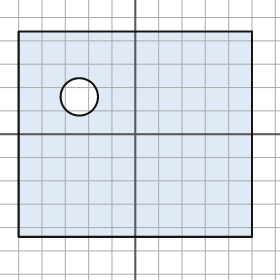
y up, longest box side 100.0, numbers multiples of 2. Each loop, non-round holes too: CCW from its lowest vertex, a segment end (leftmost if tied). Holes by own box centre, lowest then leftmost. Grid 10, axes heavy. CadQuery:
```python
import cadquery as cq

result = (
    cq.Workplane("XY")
    .moveTo(-50.0, -44.0)
    .lineTo(50.0, -44.0)
    .lineTo(50.0, 44.0)
    .lineTo(-50.0, 44.0)
    .close()
    .moveTo(-24.0, 16.0)
    .circle(8.0)
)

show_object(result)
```